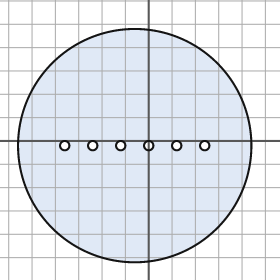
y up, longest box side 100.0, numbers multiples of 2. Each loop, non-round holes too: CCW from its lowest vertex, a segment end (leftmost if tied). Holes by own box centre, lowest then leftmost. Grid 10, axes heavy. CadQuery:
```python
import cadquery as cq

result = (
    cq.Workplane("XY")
    .moveTo(-6.0, -2.0)
    .circle(50.0)
    .moveTo(-36.0, -2.0)
    .circle(2.0)
    .moveTo(-24.0, -2.0)
    .circle(2.0)
    .moveTo(-12.0, -2.0)
    .circle(2.0)
    .moveTo(0.0, -2.0)
    .circle(2.0)
    .moveTo(12.0, -2.0)
    .circle(2.0)
    .moveTo(24.0, -2.0)
    .circle(2.0)
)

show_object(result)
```